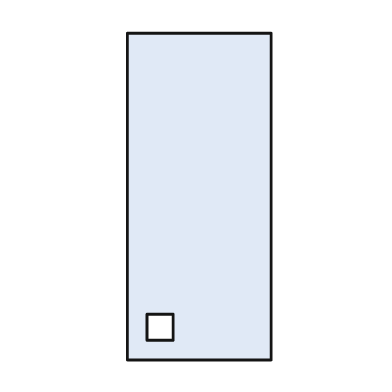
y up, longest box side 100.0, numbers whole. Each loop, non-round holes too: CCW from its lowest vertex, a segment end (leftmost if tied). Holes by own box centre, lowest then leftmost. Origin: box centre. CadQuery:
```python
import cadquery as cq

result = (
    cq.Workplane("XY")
    .moveTo(-22.0, -50.0)
    .lineTo(22.0, -50.0)
    .lineTo(22.0, 50.0)
    .lineTo(-22.0, 50.0)
    .close()
    .moveTo(-16.0, -44.0)
    .lineTo(-8.0, -44.0)
    .lineTo(-8.0, -36.0)
    .lineTo(-16.0, -36.0)
    .close()
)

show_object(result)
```